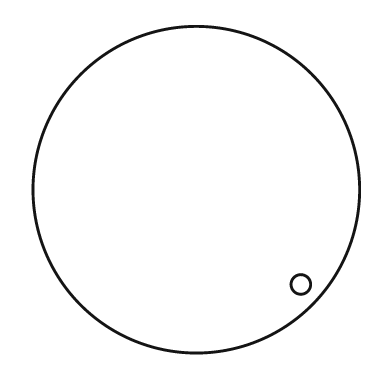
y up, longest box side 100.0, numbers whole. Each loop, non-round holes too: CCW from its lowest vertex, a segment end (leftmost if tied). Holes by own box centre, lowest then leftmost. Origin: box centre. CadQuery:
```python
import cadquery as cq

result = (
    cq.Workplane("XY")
    .moveTo(0.0, 0.0)
    .circle(50.0)
    .moveTo(32.0, -29.0)
    .circle(3.0)
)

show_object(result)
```